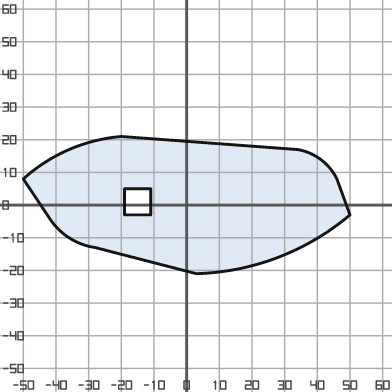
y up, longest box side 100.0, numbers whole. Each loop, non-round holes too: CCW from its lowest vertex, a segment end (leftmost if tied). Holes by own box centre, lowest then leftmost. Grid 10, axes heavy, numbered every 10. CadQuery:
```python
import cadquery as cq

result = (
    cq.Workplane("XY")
    .moveTo(3.0, -21.0)
    .threePointArc((28.0, -16.0), (50.0, -3.0))
    .lineTo(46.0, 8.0)
    .threePointArc((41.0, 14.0), (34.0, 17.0))
    .lineTo(-20.0, 21.0)
    .threePointArc((-36.0, 17.0), (-50.0, 8.0))
    .lineTo(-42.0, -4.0)
    .threePointArc((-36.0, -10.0), (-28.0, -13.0))
    .close()
    .moveTo(-19.0, -3.0)
    .lineTo(-11.0, -3.0)
    .lineTo(-11.0, 5.0)
    .lineTo(-19.0, 5.0)
    .close()
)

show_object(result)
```